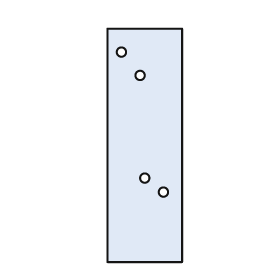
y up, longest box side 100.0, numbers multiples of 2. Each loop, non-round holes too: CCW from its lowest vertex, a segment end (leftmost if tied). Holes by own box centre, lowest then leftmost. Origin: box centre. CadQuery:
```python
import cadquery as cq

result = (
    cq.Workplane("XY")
    .moveTo(-16.0, -50.0)
    .lineTo(16.0, -50.0)
    .lineTo(16.0, 50.0)
    .lineTo(-16.0, 50.0)
    .close()
    .moveTo(8.0, -20.0)
    .circle(2.0)
    .moveTo(0.0, -14.0)
    .circle(2.0)
    .moveTo(-2.0, 30.0)
    .circle(2.0)
    .moveTo(-10.0, 40.0)
    .circle(2.0)
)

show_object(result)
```